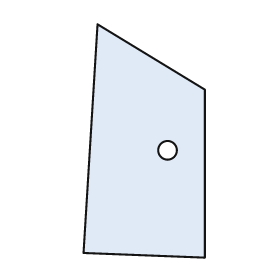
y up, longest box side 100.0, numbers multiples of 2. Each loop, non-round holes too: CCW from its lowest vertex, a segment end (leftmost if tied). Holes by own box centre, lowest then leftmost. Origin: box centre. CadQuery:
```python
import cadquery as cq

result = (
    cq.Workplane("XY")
    .moveTo(26.0, -50.0)
    .lineTo(26.0, 22.0)
    .lineTo(-20.0, 50.0)
    .lineTo(-26.0, -48.0)
    .close()
    .moveTo(10.0, -4.0)
    .circle(4.0)
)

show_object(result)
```